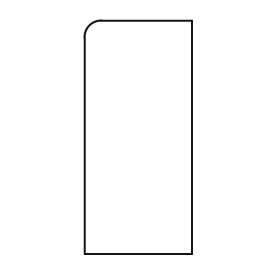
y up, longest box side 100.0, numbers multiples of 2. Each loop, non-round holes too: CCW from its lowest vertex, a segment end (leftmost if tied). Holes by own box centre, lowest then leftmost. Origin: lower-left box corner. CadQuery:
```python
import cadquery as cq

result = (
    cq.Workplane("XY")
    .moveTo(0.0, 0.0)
    .lineTo(46.0, 0.0)
    .lineTo(46.0, 100.0)
    .lineTo(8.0, 100.0)
    .threePointArc((2.0, 98.0), (0.0, 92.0))
    .close()
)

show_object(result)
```